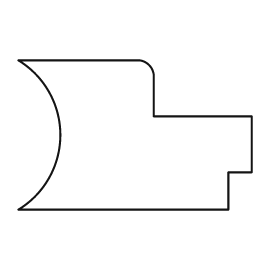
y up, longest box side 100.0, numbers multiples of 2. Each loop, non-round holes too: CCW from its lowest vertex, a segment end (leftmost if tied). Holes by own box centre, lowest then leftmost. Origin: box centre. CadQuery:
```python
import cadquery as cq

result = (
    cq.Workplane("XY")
    .moveTo(-50.0, -32.0)
    .lineTo(40.0, -32.0)
    .lineTo(40.0, -16.0)
    .lineTo(50.0, -16.0)
    .lineTo(50.0, 8.0)
    .lineTo(8.0, 8.0)
    .lineTo(8.0, 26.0)
    .threePointArc((6.0, 30.0), (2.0, 32.0))
    .lineTo(-50.0, 32.0)
    .threePointArc((-32.0, 0.0), (-50.0, -32.0))
    .close()
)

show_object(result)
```